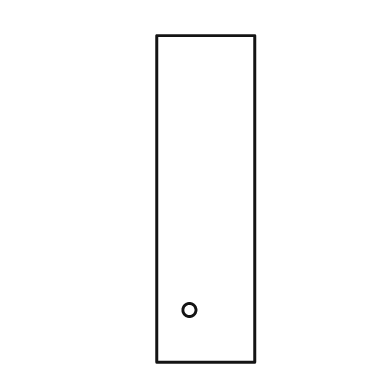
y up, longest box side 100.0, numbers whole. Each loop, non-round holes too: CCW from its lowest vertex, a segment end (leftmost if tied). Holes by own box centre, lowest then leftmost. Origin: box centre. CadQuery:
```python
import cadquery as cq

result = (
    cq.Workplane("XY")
    .moveTo(-15.0, -50.0)
    .lineTo(15.0, -50.0)
    .lineTo(15.0, 50.0)
    .lineTo(-15.0, 50.0)
    .close()
    .moveTo(-5.0, -34.0)
    .circle(2.0)
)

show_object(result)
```